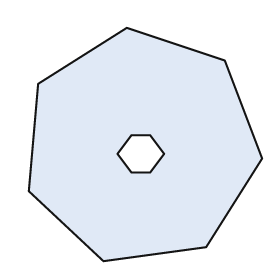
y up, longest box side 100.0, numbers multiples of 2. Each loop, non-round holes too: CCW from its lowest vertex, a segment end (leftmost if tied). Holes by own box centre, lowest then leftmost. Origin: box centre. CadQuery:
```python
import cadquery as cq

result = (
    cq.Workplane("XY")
    .moveTo(-18.0, -50.0)
    .lineTo(26.0, -44.0)
    .lineTo(50.0, -6.0)
    .lineTo(34.0, 36.0)
    .lineTo(-8.0, 50.0)
    .lineTo(-46.0, 26.0)
    .lineTo(-50.0, -20.0)
    .close()
    .moveTo(-6.0, -12.0)
    .lineTo(2.0, -12.0)
    .lineTo(8.0, -4.0)
    .lineTo(2.0, 4.0)
    .lineTo(-6.0, 4.0)
    .lineTo(-12.0, -4.0)
    .close()
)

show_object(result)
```